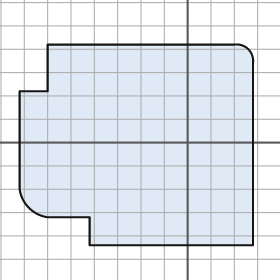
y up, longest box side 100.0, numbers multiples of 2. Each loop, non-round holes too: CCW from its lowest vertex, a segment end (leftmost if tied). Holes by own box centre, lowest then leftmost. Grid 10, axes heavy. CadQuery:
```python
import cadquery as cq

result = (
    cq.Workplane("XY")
    .moveTo(-42.0, -44.0)
    .lineTo(28.0, -44.0)
    .lineTo(28.0, 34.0)
    .threePointArc((26.0, 40.0), (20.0, 42.0))
    .lineTo(-60.0, 42.0)
    .lineTo(-60.0, 22.0)
    .lineTo(-72.0, 22.0)
    .lineTo(-72.0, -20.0)
    .threePointArc((-68.0, -28.0), (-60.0, -32.0))
    .lineTo(-42.0, -32.0)
    .close()
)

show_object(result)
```